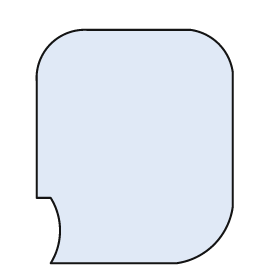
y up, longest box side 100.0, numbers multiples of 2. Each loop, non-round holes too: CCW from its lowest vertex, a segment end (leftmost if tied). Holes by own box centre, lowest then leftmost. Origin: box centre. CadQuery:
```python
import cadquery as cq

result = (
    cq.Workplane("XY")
    .moveTo(-36.0, -50.0)
    .lineTo(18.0, -50.0)
    .threePointArc((34.0, -42.0), (42.0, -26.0))
    .lineTo(42.0, 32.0)
    .threePointArc((36.0, 44.0), (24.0, 50.0))
    .lineTo(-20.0, 50.0)
    .threePointArc((-36.0, 44.0), (-42.0, 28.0))
    .lineTo(-42.0, -22.0)
    .lineTo(-36.0, -22.0)
    .threePointArc((-32.0, -36.0), (-36.0, -50.0))
    .close()
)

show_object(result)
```